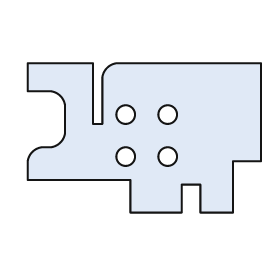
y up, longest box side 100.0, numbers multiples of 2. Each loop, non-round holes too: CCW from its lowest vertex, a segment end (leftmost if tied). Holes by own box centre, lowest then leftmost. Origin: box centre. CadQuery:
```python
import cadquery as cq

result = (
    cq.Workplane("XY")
    .moveTo(-6.0, -32.0)
    .lineTo(16.0, -32.0)
    .lineTo(16.0, -20.0)
    .lineTo(24.0, -20.0)
    .lineTo(24.0, -32.0)
    .lineTo(38.0, -32.0)
    .lineTo(38.0, -10.0)
    .lineTo(50.0, -10.0)
    .lineTo(50.0, 32.0)
    .lineTo(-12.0, 32.0)
    .threePointArc((-16.0, 30.0), (-18.0, 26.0))
    .lineTo(-18.0, 6.0)
    .lineTo(-22.0, 6.0)
    .lineTo(-22.0, 32.0)
    .lineTo(-50.0, 32.0)
    .lineTo(-50.0, 20.0)
    .lineTo(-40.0, 20.0)
    .threePointArc((-36.0, 18.0), (-34.0, 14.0))
    .lineTo(-34.0, 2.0)
    .threePointArc((-36.0, -2.0), (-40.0, -4.0))
    .lineTo(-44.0, -4.0)
    .threePointArc((-48.0, -6.0), (-50.0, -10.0))
    .lineTo(-50.0, -18.0)
    .lineTo(-6.0, -18.0)
    .close()
    .moveTo(-8.0, -8.0)
    .circle(4.0)
    .moveTo(10.0, -8.0)
    .circle(4.0)
    .moveTo(-8.0, 10.0)
    .circle(4.0)
    .moveTo(10.0, 10.0)
    .circle(4.0)
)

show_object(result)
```